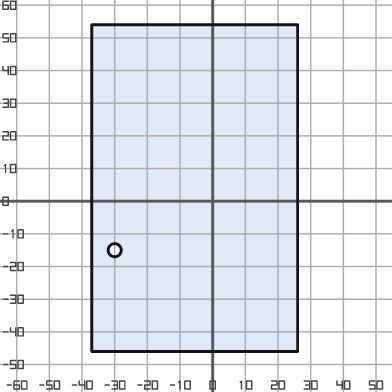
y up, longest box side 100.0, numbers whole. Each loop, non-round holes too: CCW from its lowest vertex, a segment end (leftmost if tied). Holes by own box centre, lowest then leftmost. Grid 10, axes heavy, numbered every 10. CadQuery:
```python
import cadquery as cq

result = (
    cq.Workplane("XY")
    .moveTo(-37.0, -46.0)
    .lineTo(26.0, -46.0)
    .lineTo(26.0, 54.0)
    .lineTo(-37.0, 54.0)
    .close()
    .moveTo(-30.0, -15.0)
    .circle(2.0)
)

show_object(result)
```